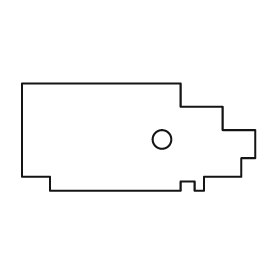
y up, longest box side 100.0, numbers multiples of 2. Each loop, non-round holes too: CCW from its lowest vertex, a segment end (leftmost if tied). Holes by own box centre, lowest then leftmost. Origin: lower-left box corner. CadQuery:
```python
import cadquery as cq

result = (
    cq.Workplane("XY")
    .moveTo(12.0, 0.0)
    .lineTo(68.0, 0.0)
    .lineTo(68.0, 4.0)
    .lineTo(74.0, 4.0)
    .lineTo(74.0, 0.0)
    .lineTo(78.0, 0.0)
    .lineTo(78.0, 6.0)
    .lineTo(94.0, 6.0)
    .lineTo(94.0, 14.0)
    .lineTo(100.0, 14.0)
    .lineTo(100.0, 26.0)
    .lineTo(86.0, 26.0)
    .lineTo(86.0, 36.0)
    .lineTo(68.0, 36.0)
    .lineTo(68.0, 46.0)
    .lineTo(0.0, 46.0)
    .lineTo(0.0, 6.0)
    .lineTo(12.0, 6.0)
    .close()
    .moveTo(60.0, 22.0)
    .circle(4.0)
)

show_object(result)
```